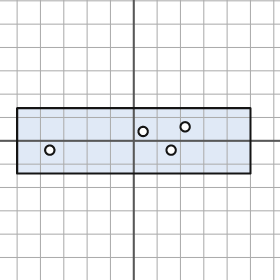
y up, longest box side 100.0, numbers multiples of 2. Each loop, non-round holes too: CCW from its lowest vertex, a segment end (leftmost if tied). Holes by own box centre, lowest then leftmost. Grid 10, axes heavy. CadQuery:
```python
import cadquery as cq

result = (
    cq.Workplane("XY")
    .moveTo(-50.0, -14.0)
    .lineTo(50.0, -14.0)
    .lineTo(50.0, 14.0)
    .lineTo(-50.0, 14.0)
    .close()
    .moveTo(-36.0, -4.0)
    .circle(2.0)
    .moveTo(16.0, -4.0)
    .circle(2.0)
    .moveTo(4.0, 4.0)
    .circle(2.0)
    .moveTo(22.0, 6.0)
    .circle(2.0)
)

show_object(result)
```